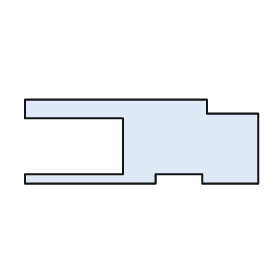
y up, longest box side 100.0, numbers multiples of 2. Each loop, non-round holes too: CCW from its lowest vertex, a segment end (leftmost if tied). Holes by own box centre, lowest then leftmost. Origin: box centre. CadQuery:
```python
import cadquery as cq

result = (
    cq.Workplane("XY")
    .moveTo(-50.0, -18.0)
    .lineTo(6.0, -18.0)
    .lineTo(6.0, -14.0)
    .lineTo(26.0, -14.0)
    .lineTo(26.0, -18.0)
    .lineTo(50.0, -18.0)
    .lineTo(50.0, 12.0)
    .lineTo(28.0, 12.0)
    .lineTo(28.0, 18.0)
    .lineTo(-50.0, 18.0)
    .lineTo(-50.0, 10.0)
    .lineTo(-8.0, 10.0)
    .lineTo(-8.0, -14.0)
    .lineTo(-50.0, -14.0)
    .close()
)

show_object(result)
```